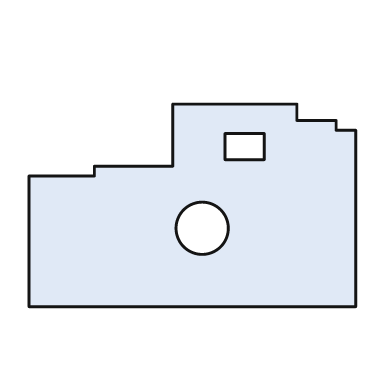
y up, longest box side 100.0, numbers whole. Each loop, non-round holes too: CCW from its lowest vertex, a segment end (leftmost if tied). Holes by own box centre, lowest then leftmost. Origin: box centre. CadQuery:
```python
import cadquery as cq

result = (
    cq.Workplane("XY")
    .moveTo(-50.0, -31.0)
    .lineTo(50.0, -31.0)
    .lineTo(50.0, 23.0)
    .lineTo(44.0, 23.0)
    .lineTo(44.0, 26.0)
    .lineTo(32.0, 26.0)
    .lineTo(32.0, 31.0)
    .lineTo(-6.0, 31.0)
    .lineTo(-6.0, 12.0)
    .lineTo(-30.0, 12.0)
    .lineTo(-30.0, 9.0)
    .lineTo(-50.0, 9.0)
    .close()
    .moveTo(3.0, -7.0)
    .circle(8.0)
    .moveTo(10.0, 14.0)
    .lineTo(22.0, 14.0)
    .lineTo(22.0, 22.0)
    .lineTo(10.0, 22.0)
    .close()
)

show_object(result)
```